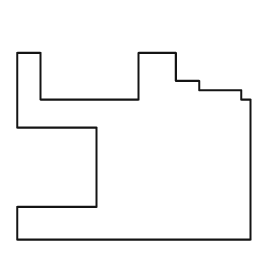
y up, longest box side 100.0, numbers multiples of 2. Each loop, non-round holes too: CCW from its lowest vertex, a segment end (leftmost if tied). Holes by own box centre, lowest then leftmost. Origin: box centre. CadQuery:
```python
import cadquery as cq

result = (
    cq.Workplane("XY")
    .moveTo(-50.0, -40.0)
    .lineTo(50.0, -40.0)
    .lineTo(50.0, 20.0)
    .lineTo(46.0, 20.0)
    .lineTo(46.0, 24.0)
    .lineTo(28.0, 24.0)
    .lineTo(28.0, 28.0)
    .lineTo(18.0, 28.0)
    .lineTo(18.0, 40.0)
    .lineTo(2.0, 40.0)
    .lineTo(2.0, 20.0)
    .lineTo(-40.0, 20.0)
    .lineTo(-40.0, 40.0)
    .lineTo(-50.0, 40.0)
    .lineTo(-50.0, 8.0)
    .lineTo(-16.0, 8.0)
    .lineTo(-16.0, -26.0)
    .lineTo(-50.0, -26.0)
    .close()
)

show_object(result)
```